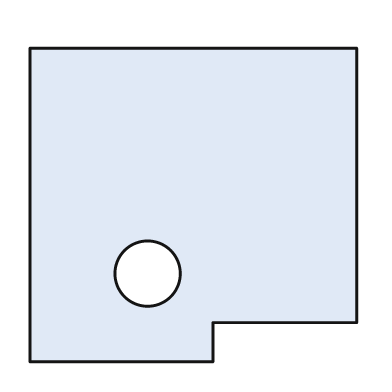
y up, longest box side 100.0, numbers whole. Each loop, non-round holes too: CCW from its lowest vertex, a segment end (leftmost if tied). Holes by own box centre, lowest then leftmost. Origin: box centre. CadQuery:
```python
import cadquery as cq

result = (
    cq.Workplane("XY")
    .moveTo(-50.0, -48.0)
    .lineTo(6.0, -48.0)
    .lineTo(6.0, -36.0)
    .lineTo(50.0, -36.0)
    .lineTo(50.0, 48.0)
    .lineTo(-50.0, 48.0)
    .close()
    .moveTo(-14.0, -21.0)
    .circle(10.0)
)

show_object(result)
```